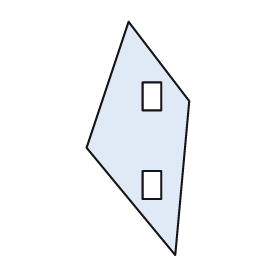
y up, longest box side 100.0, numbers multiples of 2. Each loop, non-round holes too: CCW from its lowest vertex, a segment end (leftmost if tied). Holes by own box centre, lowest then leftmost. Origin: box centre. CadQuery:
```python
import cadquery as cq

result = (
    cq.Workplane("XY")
    .moveTo(16.0, -50.0)
    .lineTo(22.0, 16.0)
    .lineTo(-4.0, 50.0)
    .lineTo(-22.0, -4.0)
    .close()
    .moveTo(2.0, -26.0)
    .lineTo(10.0, -26.0)
    .lineTo(10.0, -14.0)
    .lineTo(2.0, -14.0)
    .close()
    .moveTo(2.0, 12.0)
    .lineTo(10.0, 12.0)
    .lineTo(10.0, 24.0)
    .lineTo(2.0, 24.0)
    .close()
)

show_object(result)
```